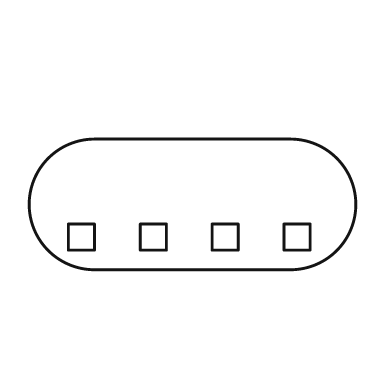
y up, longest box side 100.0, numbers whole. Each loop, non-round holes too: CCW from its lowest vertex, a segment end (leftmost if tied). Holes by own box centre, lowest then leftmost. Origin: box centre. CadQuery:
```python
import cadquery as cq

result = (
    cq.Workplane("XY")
    .moveTo(-30.0, -20.0)
    .lineTo(30.0, -20.0)
    .threePointArc((50.0, 0.0), (30.0, 20.0))
    .lineTo(-30.0, 20.0)
    .threePointArc((-50.0, 0.0), (-30.0, -20.0))
    .close()
    .moveTo(-38.0, -14.0)
    .lineTo(-30.0, -14.0)
    .lineTo(-30.0, -6.0)
    .lineTo(-38.0, -6.0)
    .close()
    .moveTo(-16.0, -14.0)
    .lineTo(-8.0, -14.0)
    .lineTo(-8.0, -6.0)
    .lineTo(-16.0, -6.0)
    .close()
    .moveTo(6.0, -14.0)
    .lineTo(14.0, -14.0)
    .lineTo(14.0, -6.0)
    .lineTo(6.0, -6.0)
    .close()
    .moveTo(28.0, -14.0)
    .lineTo(36.0, -14.0)
    .lineTo(36.0, -6.0)
    .lineTo(28.0, -6.0)
    .close()
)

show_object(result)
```